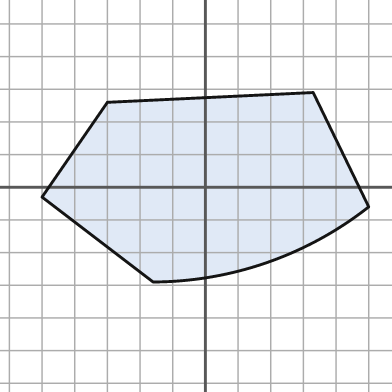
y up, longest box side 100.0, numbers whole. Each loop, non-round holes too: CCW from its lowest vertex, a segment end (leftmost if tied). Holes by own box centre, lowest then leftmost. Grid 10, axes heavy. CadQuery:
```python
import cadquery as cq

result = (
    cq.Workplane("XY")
    .moveTo(-16.0, -29.0)
    .threePointArc((19.0, -23.0), (50.0, -6.0))
    .lineTo(33.0, 29.0)
    .lineTo(-30.0, 26.0)
    .lineTo(-50.0, -3.0)
    .close()
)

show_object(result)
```